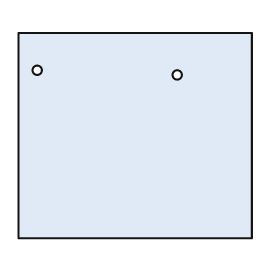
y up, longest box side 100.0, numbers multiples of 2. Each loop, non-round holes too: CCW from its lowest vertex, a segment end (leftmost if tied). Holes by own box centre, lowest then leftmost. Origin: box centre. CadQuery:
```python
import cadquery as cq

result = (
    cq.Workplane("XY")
    .moveTo(-50.0, -44.0)
    .lineTo(50.0, -44.0)
    .lineTo(50.0, 44.0)
    .lineTo(-50.0, 44.0)
    .close()
    .moveTo(18.0, 26.0)
    .circle(2.0)
    .moveTo(-42.0, 28.0)
    .circle(2.0)
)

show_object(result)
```